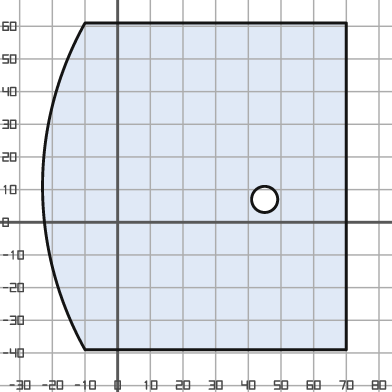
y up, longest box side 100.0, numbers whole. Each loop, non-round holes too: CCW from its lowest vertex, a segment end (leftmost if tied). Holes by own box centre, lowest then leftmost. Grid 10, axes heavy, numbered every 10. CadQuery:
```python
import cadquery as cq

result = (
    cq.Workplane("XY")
    .moveTo(-10.0, -39.0)
    .lineTo(70.0, -39.0)
    .lineTo(70.0, 61.0)
    .lineTo(-10.0, 61.0)
    .threePointArc((-23.0, 11.0), (-10.0, -39.0))
    .close()
    .moveTo(45.0, 7.0)
    .circle(4.0)
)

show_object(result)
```